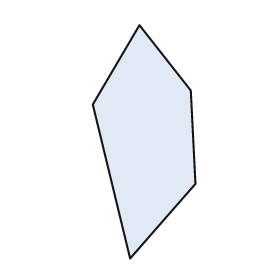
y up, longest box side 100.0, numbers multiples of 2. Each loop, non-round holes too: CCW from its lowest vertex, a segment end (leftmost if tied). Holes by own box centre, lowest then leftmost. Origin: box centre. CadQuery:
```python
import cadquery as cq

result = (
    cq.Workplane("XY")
    .moveTo(-6.0, -50.0)
    .lineTo(22.0, -18.0)
    .lineTo(20.0, 22.0)
    .lineTo(-2.0, 50.0)
    .lineTo(-22.0, 16.0)
    .close()
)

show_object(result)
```